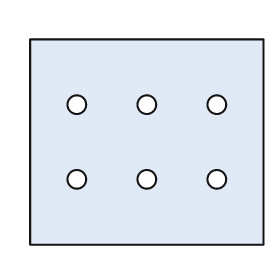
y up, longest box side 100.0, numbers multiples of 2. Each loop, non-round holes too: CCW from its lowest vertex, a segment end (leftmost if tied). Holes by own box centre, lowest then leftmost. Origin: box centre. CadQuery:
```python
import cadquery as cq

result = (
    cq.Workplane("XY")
    .moveTo(-50.0, -44.0)
    .lineTo(50.0, -44.0)
    .lineTo(50.0, 44.0)
    .lineTo(-50.0, 44.0)
    .close()
    .moveTo(-30.0, -16.0)
    .circle(4.0)
    .moveTo(0.0, -16.0)
    .circle(4.0)
    .moveTo(30.0, -16.0)
    .circle(4.0)
    .moveTo(-30.0, 16.0)
    .circle(4.0)
    .moveTo(0.0, 16.0)
    .circle(4.0)
    .moveTo(30.0, 16.0)
    .circle(4.0)
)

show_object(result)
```